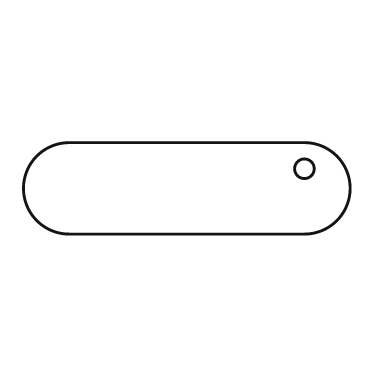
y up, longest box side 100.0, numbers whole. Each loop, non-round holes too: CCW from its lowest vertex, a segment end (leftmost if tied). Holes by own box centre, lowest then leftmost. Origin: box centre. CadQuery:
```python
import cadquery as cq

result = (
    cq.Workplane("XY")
    .moveTo(-36.0, -14.0)
    .lineTo(36.0, -14.0)
    .threePointArc((50.0, 0.0), (36.0, 14.0))
    .lineTo(-36.0, 14.0)
    .threePointArc((-50.0, 0.0), (-36.0, -14.0))
    .close()
    .moveTo(36.0, 6.0)
    .circle(3.0)
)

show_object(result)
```